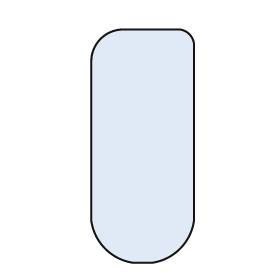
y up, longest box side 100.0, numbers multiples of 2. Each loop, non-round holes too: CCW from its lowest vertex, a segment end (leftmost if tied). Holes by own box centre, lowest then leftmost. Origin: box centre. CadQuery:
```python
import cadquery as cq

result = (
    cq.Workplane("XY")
    .moveTo(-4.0, -50.0)
    .lineTo(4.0, -50.0)
    .threePointArc((16.0, -44.0), (22.0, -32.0))
    .lineTo(22.0, 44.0)
    .threePointArc((20.0, 48.0), (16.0, 50.0))
    .lineTo(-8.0, 50.0)
    .threePointArc((-18.0, 46.0), (-22.0, 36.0))
    .lineTo(-22.0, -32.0)
    .threePointArc((-16.0, -44.0), (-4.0, -50.0))
    .close()
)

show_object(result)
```